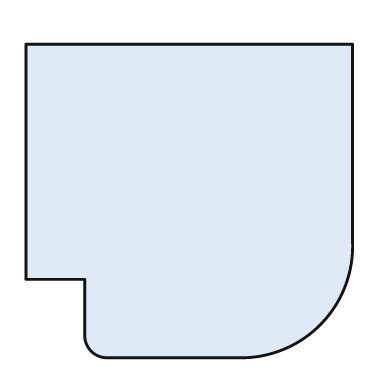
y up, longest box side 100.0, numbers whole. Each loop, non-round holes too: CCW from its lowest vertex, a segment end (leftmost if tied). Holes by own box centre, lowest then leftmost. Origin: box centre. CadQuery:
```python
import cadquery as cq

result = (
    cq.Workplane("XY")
    .moveTo(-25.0, -48.0)
    .lineTo(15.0, -48.0)
    .threePointArc((40.0, -38.0), (50.0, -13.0))
    .lineTo(50.0, 48.0)
    .lineTo(-50.0, 48.0)
    .lineTo(-50.0, -24.0)
    .lineTo(-32.0, -24.0)
    .lineTo(-32.0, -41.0)
    .threePointArc((-30.0, -46.0), (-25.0, -48.0))
    .close()
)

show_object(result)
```